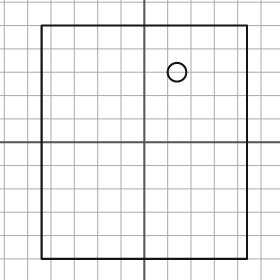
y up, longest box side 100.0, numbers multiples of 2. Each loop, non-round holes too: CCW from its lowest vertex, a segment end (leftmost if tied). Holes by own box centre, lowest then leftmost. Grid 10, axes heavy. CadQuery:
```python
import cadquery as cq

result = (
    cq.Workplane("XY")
    .moveTo(-44.0, -50.0)
    .lineTo(44.0, -50.0)
    .lineTo(44.0, 50.0)
    .lineTo(-44.0, 50.0)
    .close()
    .moveTo(14.0, 30.0)
    .circle(4.0)
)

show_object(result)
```